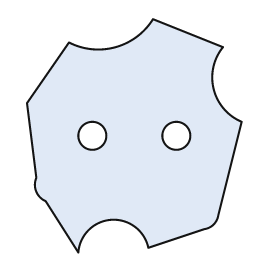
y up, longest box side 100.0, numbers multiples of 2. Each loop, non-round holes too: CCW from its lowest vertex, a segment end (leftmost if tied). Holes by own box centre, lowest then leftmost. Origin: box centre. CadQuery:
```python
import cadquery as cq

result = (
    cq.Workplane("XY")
    .moveTo(-24.0, -50.0)
    .threePointArc((-10.0, -36.0), (6.0, -48.0))
    .lineTo(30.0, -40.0)
    .threePointArc((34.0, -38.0), (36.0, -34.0))
    .lineTo(46.0, 6.0)
    .threePointArc((34.0, 20.0), (38.0, 38.0))
    .lineTo(8.0, 50.0)
    .threePointArc((-8.0, 38.0), (-28.0, 40.0))
    .lineTo(-46.0, 14.0)
    .lineTo(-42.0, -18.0)
    .threePointArc((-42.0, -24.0), (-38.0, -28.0))
    .close()
    .moveTo(-18.0, 0.0)
    .circle(6.0)
    .moveTo(18.0, 0.0)
    .circle(6.0)
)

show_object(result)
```